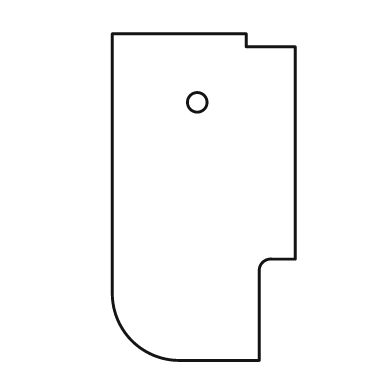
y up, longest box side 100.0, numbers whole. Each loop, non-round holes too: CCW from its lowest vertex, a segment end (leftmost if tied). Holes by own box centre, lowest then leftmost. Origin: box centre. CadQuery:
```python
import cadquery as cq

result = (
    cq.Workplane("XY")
    .moveTo(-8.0, -50.0)
    .lineTo(17.0, -50.0)
    .lineTo(17.0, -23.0)
    .threePointArc((18.0, -20.0), (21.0, -19.0))
    .lineTo(28.0, -19.0)
    .lineTo(28.0, 46.0)
    .lineTo(13.0, 46.0)
    .lineTo(13.0, 50.0)
    .lineTo(-28.0, 50.0)
    .lineTo(-28.0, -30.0)
    .threePointArc((-22.0, -44.0), (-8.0, -50.0))
    .close()
    .moveTo(-2.0, 29.0)
    .circle(3.0)
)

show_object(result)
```